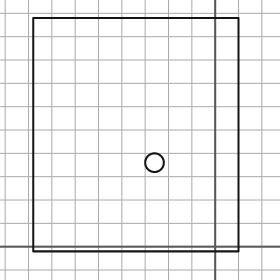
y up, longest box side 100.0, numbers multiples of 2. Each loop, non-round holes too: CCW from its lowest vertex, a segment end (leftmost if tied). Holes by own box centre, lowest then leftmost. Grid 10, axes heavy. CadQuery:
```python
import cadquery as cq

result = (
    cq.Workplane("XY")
    .moveTo(-78.0, -2.0)
    .lineTo(10.0, -2.0)
    .lineTo(10.0, 98.0)
    .lineTo(-78.0, 98.0)
    .close()
    .moveTo(-26.0, 36.0)
    .circle(4.0)
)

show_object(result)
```